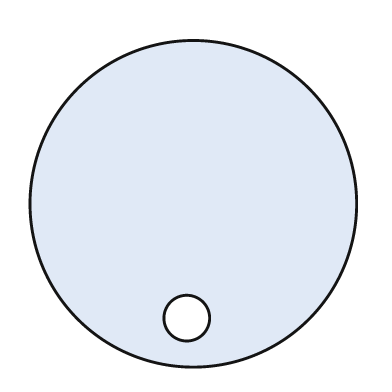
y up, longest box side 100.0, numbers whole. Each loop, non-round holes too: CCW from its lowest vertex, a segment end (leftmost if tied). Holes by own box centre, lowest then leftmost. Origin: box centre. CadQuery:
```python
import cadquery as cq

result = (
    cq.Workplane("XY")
    .moveTo(0.0, 0.0)
    .circle(50.0)
    .moveTo(-2.0, -35.0)
    .circle(7.0)
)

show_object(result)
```